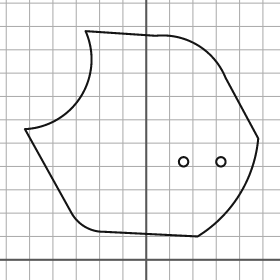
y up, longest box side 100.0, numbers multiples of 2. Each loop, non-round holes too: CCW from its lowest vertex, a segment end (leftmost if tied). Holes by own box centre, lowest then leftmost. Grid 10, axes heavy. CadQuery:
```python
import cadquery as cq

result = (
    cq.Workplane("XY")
    .moveTo(22.0, 10.0)
    .threePointArc((40.0, 28.0), (48.0, 52.0))
    .lineTo(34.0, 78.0)
    .threePointArc((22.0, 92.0), (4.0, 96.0))
    .lineTo(-26.0, 98.0)
    .threePointArc((-28.0, 70.0), (-52.0, 56.0))
    .lineTo(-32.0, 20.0)
    .threePointArc((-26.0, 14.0), (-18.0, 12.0))
    .close()
    .moveTo(16.0, 42.0)
    .circle(2.0)
    .moveTo(32.0, 42.0)
    .circle(2.0)
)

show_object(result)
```